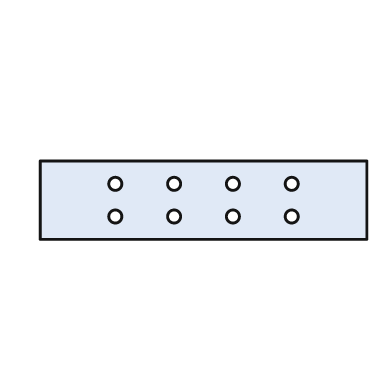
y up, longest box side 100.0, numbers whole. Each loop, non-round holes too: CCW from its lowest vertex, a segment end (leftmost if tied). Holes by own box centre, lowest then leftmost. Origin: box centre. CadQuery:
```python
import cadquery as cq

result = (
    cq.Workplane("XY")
    .moveTo(-50.0, -12.0)
    .lineTo(50.0, -12.0)
    .lineTo(50.0, 12.0)
    .lineTo(-50.0, 12.0)
    .close()
    .moveTo(-27.0, -5.0)
    .circle(2.0)
    .moveTo(-9.0, -5.0)
    .circle(2.0)
    .moveTo(9.0, -5.0)
    .circle(2.0)
    .moveTo(27.0, -5.0)
    .circle(2.0)
    .moveTo(-27.0, 5.0)
    .circle(2.0)
    .moveTo(-9.0, 5.0)
    .circle(2.0)
    .moveTo(9.0, 5.0)
    .circle(2.0)
    .moveTo(27.0, 5.0)
    .circle(2.0)
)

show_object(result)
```